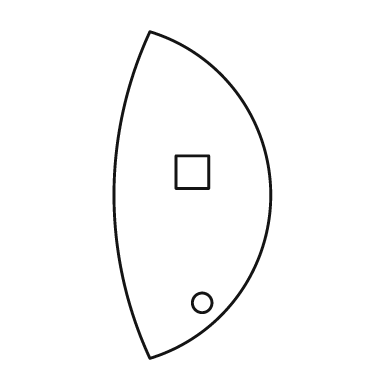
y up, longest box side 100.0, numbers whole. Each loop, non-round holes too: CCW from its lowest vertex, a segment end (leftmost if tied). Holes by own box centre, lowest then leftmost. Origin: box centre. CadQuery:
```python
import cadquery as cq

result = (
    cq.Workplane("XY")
    .moveTo(-13.0, -50.0)
    .threePointArc((24.0, 0.0), (-13.0, 50.0))
    .threePointArc((-24.0, 0.0), (-13.0, -50.0))
    .close()
    .moveTo(3.0, -33.0)
    .circle(3.0)
    .moveTo(-5.0, 2.0)
    .lineTo(5.0, 2.0)
    .lineTo(5.0, 12.0)
    .lineTo(-5.0, 12.0)
    .close()
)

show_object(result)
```